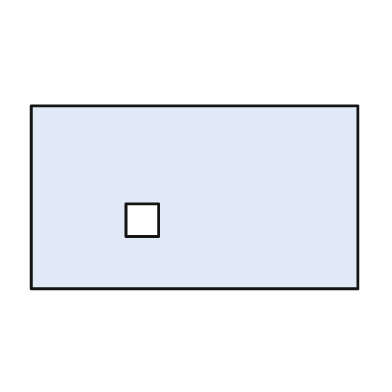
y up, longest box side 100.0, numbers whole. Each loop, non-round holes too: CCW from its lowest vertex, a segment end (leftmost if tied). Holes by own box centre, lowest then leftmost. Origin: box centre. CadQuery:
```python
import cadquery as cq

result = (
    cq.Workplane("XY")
    .moveTo(-50.0, -28.0)
    .lineTo(50.0, -28.0)
    .lineTo(50.0, 28.0)
    .lineTo(-50.0, 28.0)
    .close()
    .moveTo(-21.0, -12.0)
    .lineTo(-11.0, -12.0)
    .lineTo(-11.0, -2.0)
    .lineTo(-21.0, -2.0)
    .close()
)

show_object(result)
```